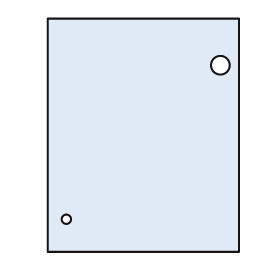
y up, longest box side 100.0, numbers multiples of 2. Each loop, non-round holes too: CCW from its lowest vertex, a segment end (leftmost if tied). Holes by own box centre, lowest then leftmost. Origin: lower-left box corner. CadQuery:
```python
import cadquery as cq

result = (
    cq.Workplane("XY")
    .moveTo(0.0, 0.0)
    .lineTo(82.0, 0.0)
    .lineTo(82.0, 100.0)
    .lineTo(0.0, 100.0)
    .close()
    .moveTo(8.0, 14.0)
    .circle(2.0)
    .moveTo(74.0, 80.0)
    .circle(4.0)
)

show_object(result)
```